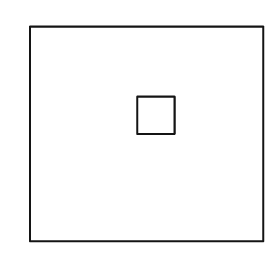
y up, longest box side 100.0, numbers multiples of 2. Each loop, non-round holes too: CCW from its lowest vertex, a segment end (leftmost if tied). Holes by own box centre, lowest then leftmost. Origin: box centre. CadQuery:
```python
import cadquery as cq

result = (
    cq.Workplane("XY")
    .moveTo(-50.0, -46.0)
    .lineTo(50.0, -46.0)
    .lineTo(50.0, 46.0)
    .lineTo(-50.0, 46.0)
    .close()
    .moveTo(-4.0, 0.0)
    .lineTo(12.0, 0.0)
    .lineTo(12.0, 16.0)
    .lineTo(-4.0, 16.0)
    .close()
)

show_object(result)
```